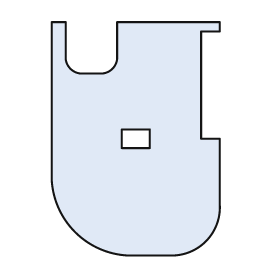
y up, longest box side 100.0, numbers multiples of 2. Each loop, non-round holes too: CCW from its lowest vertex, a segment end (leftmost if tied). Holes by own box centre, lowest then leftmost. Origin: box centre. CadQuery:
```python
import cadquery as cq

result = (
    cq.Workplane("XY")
    .moveTo(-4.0, -50.0)
    .lineTo(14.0, -50.0)
    .threePointArc((30.0, -44.0), (36.0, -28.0))
    .lineTo(36.0, 0.0)
    .lineTo(28.0, 0.0)
    .lineTo(28.0, 46.0)
    .lineTo(36.0, 46.0)
    .lineTo(36.0, 50.0)
    .lineTo(-8.0, 50.0)
    .lineTo(-8.0, 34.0)
    .threePointArc((-10.0, 30.0), (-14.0, 28.0))
    .lineTo(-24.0, 28.0)
    .threePointArc((-28.0, 30.0), (-30.0, 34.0))
    .lineTo(-30.0, 50.0)
    .lineTo(-36.0, 50.0)
    .lineTo(-36.0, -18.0)
    .threePointArc((-26.0, -40.0), (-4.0, -50.0))
    .close()
    .moveTo(-6.0, -4.0)
    .lineTo(6.0, -4.0)
    .lineTo(6.0, 4.0)
    .lineTo(-6.0, 4.0)
    .close()
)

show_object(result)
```